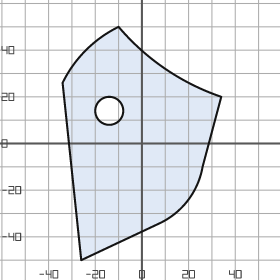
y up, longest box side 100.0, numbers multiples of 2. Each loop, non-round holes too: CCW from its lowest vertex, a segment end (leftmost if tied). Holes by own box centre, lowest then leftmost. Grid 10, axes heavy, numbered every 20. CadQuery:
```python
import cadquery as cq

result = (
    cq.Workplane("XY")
    .moveTo(-26.0, -50.0)
    .lineTo(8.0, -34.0)
    .threePointArc((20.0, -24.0), (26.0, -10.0))
    .lineTo(34.0, 20.0)
    .threePointArc((10.0, 32.0), (-10.0, 50.0))
    .threePointArc((-24.0, 40.0), (-34.0, 26.0))
    .close()
    .moveTo(-14.0, 14.0)
    .circle(6.0)
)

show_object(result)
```